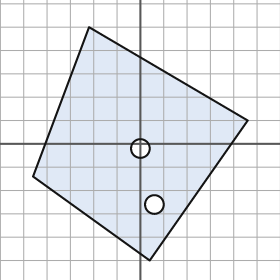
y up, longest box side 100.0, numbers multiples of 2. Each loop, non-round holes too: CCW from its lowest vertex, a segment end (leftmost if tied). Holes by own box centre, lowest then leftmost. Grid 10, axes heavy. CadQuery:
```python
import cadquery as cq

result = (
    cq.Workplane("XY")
    .moveTo(4.0, -50.0)
    .lineTo(46.0, 10.0)
    .lineTo(-22.0, 50.0)
    .lineTo(-46.0, -14.0)
    .close()
    .moveTo(6.0, -26.0)
    .circle(4.0)
    .moveTo(0.0, -2.0)
    .circle(4.0)
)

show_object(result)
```